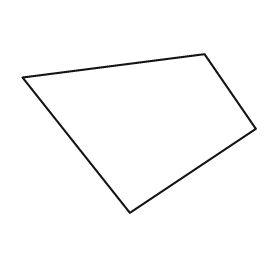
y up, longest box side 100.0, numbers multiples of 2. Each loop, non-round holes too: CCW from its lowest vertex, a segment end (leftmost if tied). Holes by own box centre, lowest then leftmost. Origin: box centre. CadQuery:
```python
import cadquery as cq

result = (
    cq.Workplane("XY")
    .moveTo(-4.0, -34.0)
    .lineTo(50.0, 2.0)
    .lineTo(28.0, 34.0)
    .lineTo(-50.0, 24.0)
    .close()
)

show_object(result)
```